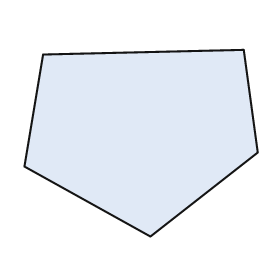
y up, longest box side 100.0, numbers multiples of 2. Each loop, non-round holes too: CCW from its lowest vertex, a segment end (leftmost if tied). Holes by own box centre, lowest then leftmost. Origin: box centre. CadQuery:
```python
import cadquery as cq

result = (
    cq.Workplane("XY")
    .moveTo(4.0, -40.0)
    .lineTo(50.0, -4.0)
    .lineTo(44.0, 40.0)
    .lineTo(-42.0, 38.0)
    .lineTo(-50.0, -10.0)
    .close()
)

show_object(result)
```